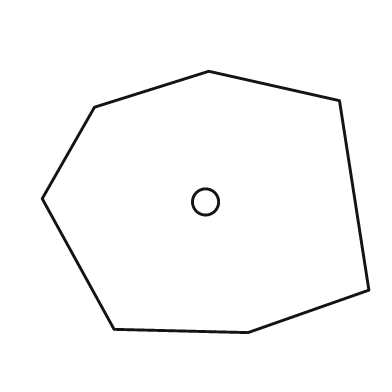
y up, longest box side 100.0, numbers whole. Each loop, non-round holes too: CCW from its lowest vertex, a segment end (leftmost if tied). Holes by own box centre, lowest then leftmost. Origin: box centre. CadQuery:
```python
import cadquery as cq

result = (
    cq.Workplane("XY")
    .moveTo(13.0, -40.0)
    .lineTo(50.0, -27.0)
    .lineTo(41.0, 31.0)
    .lineTo(1.0, 40.0)
    .lineTo(-34.0, 29.0)
    .lineTo(-50.0, 1.0)
    .lineTo(-28.0, -39.0)
    .close()
    .moveTo(0.0, 0.0)
    .circle(4.0)
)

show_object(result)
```